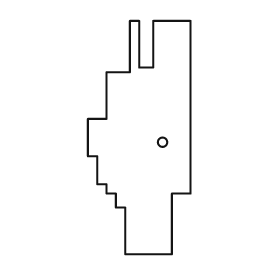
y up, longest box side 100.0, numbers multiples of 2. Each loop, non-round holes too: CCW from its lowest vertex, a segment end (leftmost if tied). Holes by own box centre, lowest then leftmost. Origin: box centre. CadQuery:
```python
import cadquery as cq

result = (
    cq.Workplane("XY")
    .moveTo(-6.0, -50.0)
    .lineTo(14.0, -50.0)
    .lineTo(14.0, -24.0)
    .lineTo(22.0, -24.0)
    .lineTo(22.0, 50.0)
    .lineTo(6.0, 50.0)
    .lineTo(6.0, 30.0)
    .lineTo(0.0, 30.0)
    .lineTo(0.0, 50.0)
    .lineTo(-4.0, 50.0)
    .lineTo(-4.0, 28.0)
    .lineTo(-14.0, 28.0)
    .lineTo(-14.0, 8.0)
    .lineTo(-22.0, 8.0)
    .lineTo(-22.0, -8.0)
    .lineTo(-18.0, -8.0)
    .lineTo(-18.0, -20.0)
    .lineTo(-14.0, -20.0)
    .lineTo(-14.0, -24.0)
    .lineTo(-10.0, -24.0)
    .lineTo(-10.0, -30.0)
    .lineTo(-6.0, -30.0)
    .close()
    .moveTo(10.0, -2.0)
    .circle(2.0)
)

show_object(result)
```